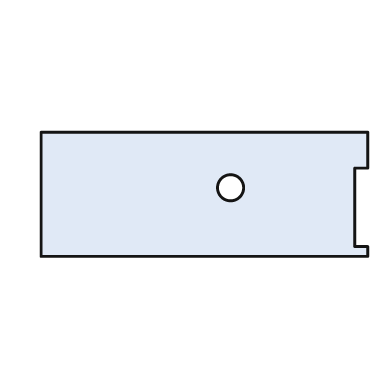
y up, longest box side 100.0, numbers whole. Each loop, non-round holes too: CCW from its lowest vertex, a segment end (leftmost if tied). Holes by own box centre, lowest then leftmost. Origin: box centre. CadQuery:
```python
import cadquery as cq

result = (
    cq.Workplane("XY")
    .moveTo(-50.0, -19.0)
    .lineTo(50.0, -19.0)
    .lineTo(50.0, -16.0)
    .lineTo(46.0, -16.0)
    .lineTo(46.0, 8.0)
    .lineTo(50.0, 8.0)
    .lineTo(50.0, 19.0)
    .lineTo(-50.0, 19.0)
    .close()
    .moveTo(8.0, 2.0)
    .circle(4.0)
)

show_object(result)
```